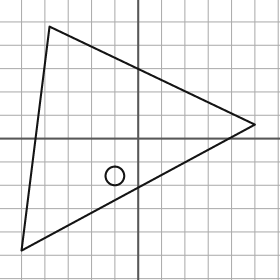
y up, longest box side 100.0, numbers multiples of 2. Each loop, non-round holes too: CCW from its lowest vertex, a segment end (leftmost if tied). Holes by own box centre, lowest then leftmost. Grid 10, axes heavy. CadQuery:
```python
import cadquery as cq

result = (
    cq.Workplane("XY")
    .moveTo(-50.0, -48.0)
    .lineTo(50.0, 6.0)
    .lineTo(-38.0, 48.0)
    .close()
    .moveTo(-10.0, -16.0)
    .circle(4.0)
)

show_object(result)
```